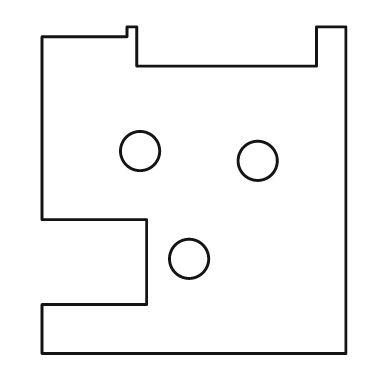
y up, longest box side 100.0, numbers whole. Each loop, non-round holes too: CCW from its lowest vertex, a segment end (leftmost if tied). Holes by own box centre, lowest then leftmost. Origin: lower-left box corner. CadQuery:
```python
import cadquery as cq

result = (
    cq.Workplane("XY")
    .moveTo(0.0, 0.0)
    .lineTo(93.0, 0.0)
    .lineTo(93.0, 100.0)
    .lineTo(84.0, 100.0)
    .lineTo(84.0, 88.0)
    .lineTo(29.0, 88.0)
    .lineTo(29.0, 100.0)
    .lineTo(26.0, 100.0)
    .lineTo(26.0, 97.0)
    .lineTo(0.0, 97.0)
    .lineTo(0.0, 41.0)
    .lineTo(32.0, 41.0)
    .lineTo(32.0, 15.0)
    .lineTo(0.0, 15.0)
    .close()
    .moveTo(45.0, 29.0)
    .circle(6.0)
    .moveTo(66.0, 59.0)
    .circle(6.0)
    .moveTo(30.0, 62.0)
    .circle(6.0)
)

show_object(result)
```